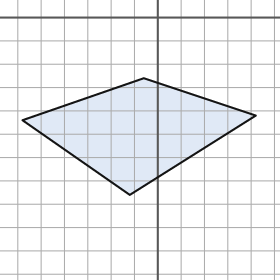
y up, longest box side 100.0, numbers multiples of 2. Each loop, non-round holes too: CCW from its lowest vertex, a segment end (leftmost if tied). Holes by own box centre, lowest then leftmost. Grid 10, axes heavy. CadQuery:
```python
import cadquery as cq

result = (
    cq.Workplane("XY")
    .moveTo(-12.0, -76.0)
    .lineTo(42.0, -42.0)
    .lineTo(-6.0, -26.0)
    .lineTo(-58.0, -44.0)
    .close()
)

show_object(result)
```